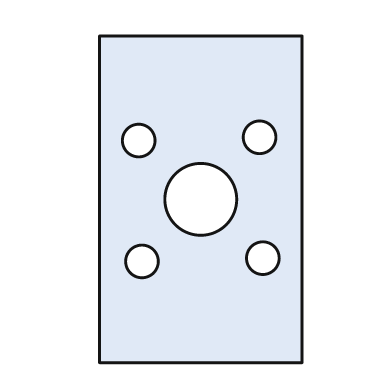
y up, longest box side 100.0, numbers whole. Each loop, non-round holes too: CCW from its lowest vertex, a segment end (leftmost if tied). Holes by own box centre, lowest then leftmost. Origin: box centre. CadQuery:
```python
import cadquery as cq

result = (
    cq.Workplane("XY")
    .moveTo(-31.0, -50.0)
    .lineTo(31.0, -50.0)
    .lineTo(31.0, 50.0)
    .lineTo(-31.0, 50.0)
    .close()
    .moveTo(-18.0, -19.0)
    .circle(5.0)
    .moveTo(19.0, -18.0)
    .circle(5.0)
    .moveTo(0.0, 0.0)
    .circle(11.0)
    .moveTo(-19.0, 18.0)
    .circle(5.0)
    .moveTo(18.0, 19.0)
    .circle(5.0)
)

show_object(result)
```